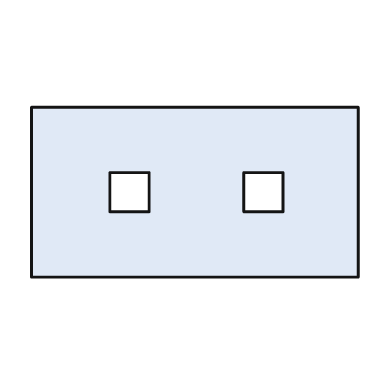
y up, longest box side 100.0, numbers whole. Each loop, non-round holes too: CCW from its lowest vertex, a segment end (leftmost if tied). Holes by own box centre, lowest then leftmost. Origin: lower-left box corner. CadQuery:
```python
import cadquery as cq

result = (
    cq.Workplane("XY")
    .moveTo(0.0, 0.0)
    .lineTo(100.0, 0.0)
    .lineTo(100.0, 52.0)
    .lineTo(0.0, 52.0)
    .close()
    .moveTo(24.0, 20.0)
    .lineTo(36.0, 20.0)
    .lineTo(36.0, 32.0)
    .lineTo(24.0, 32.0)
    .close()
    .moveTo(65.0, 20.0)
    .lineTo(77.0, 20.0)
    .lineTo(77.0, 32.0)
    .lineTo(65.0, 32.0)
    .close()
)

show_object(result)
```